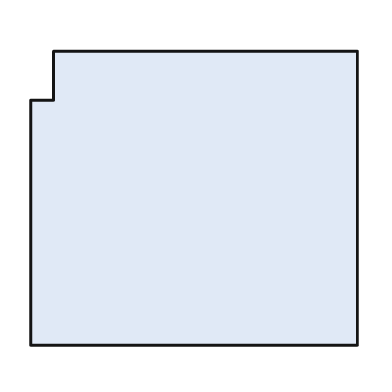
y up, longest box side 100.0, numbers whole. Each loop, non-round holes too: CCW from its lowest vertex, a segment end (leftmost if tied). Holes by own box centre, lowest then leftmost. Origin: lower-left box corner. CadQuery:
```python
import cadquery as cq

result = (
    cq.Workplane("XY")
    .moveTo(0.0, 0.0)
    .lineTo(100.0, 0.0)
    .lineTo(100.0, 90.0)
    .lineTo(7.0, 90.0)
    .lineTo(7.0, 75.0)
    .lineTo(0.0, 75.0)
    .close()
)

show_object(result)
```